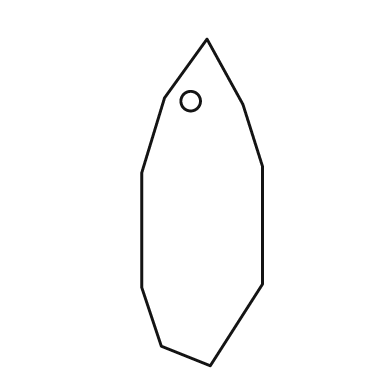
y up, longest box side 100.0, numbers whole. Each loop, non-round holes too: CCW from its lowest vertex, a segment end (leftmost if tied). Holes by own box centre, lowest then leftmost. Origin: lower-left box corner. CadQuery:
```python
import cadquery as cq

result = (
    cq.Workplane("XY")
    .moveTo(21.0, 0.0)
    .lineTo(37.0, 25.0)
    .lineTo(37.0, 61.0)
    .lineTo(31.0, 80.0)
    .lineTo(20.0, 100.0)
    .lineTo(7.0, 82.0)
    .lineTo(0.0, 59.0)
    .lineTo(0.0, 24.0)
    .lineTo(6.0, 6.0)
    .close()
    .moveTo(15.0, 81.0)
    .circle(3.0)
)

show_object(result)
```